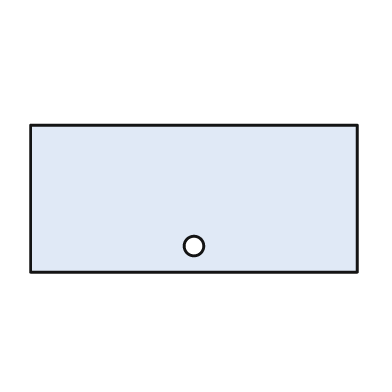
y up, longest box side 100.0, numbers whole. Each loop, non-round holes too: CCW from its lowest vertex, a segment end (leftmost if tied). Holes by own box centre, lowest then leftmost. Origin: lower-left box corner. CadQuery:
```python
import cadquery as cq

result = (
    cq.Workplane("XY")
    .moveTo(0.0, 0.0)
    .lineTo(100.0, 0.0)
    .lineTo(100.0, 45.0)
    .lineTo(0.0, 45.0)
    .close()
    .moveTo(50.0, 8.0)
    .circle(3.0)
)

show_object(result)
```